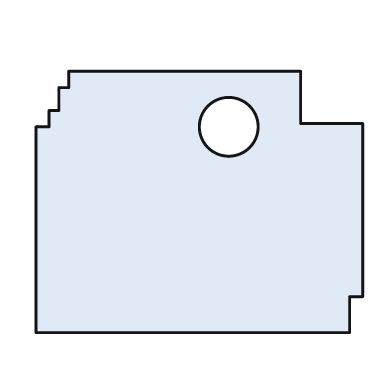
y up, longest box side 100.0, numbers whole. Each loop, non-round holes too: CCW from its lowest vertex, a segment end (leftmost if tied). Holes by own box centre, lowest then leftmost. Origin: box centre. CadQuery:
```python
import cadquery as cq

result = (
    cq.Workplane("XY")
    .moveTo(-50.0, -40.0)
    .lineTo(46.0, -40.0)
    .lineTo(46.0, -29.0)
    .lineTo(50.0, -29.0)
    .lineTo(50.0, 24.0)
    .lineTo(31.0, 24.0)
    .lineTo(31.0, 40.0)
    .lineTo(-40.0, 40.0)
    .lineTo(-40.0, 35.0)
    .lineTo(-43.0, 35.0)
    .lineTo(-43.0, 28.0)
    .lineTo(-46.0, 28.0)
    .lineTo(-46.0, 23.0)
    .lineTo(-50.0, 23.0)
    .close()
    .moveTo(9.0, 23.0)
    .circle(9.0)
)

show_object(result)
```